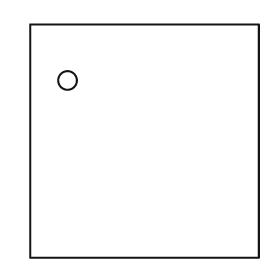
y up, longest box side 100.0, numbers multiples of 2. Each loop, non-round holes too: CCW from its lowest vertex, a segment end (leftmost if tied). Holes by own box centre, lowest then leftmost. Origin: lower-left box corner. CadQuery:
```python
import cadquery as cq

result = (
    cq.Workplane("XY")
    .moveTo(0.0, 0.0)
    .lineTo(98.0, 0.0)
    .lineTo(98.0, 100.0)
    .lineTo(0.0, 100.0)
    .close()
    .moveTo(16.0, 76.0)
    .circle(4.0)
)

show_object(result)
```